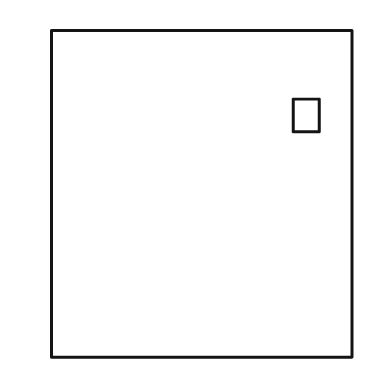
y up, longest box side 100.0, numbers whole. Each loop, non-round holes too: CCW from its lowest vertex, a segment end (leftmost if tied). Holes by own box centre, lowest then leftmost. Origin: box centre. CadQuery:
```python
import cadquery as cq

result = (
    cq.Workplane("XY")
    .moveTo(-46.0, -50.0)
    .lineTo(46.0, -50.0)
    .lineTo(46.0, 50.0)
    .lineTo(-46.0, 50.0)
    .close()
    .moveTo(28.0, 19.0)
    .lineTo(36.0, 19.0)
    .lineTo(36.0, 29.0)
    .lineTo(28.0, 29.0)
    .close()
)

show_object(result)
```